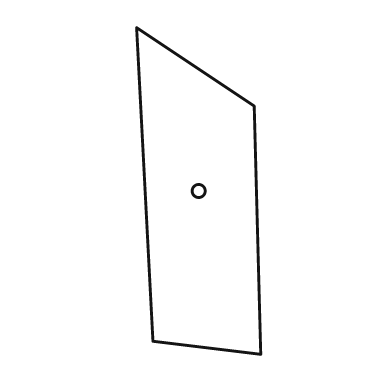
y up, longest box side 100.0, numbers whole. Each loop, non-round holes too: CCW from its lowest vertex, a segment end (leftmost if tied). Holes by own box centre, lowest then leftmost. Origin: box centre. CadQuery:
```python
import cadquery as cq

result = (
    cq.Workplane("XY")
    .moveTo(19.0, -50.0)
    .lineTo(17.0, 26.0)
    .lineTo(-19.0, 50.0)
    .lineTo(-14.0, -46.0)
    .close()
    .moveTo(0.0, 0.0)
    .circle(2.0)
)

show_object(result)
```